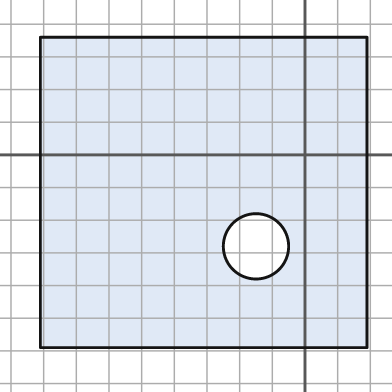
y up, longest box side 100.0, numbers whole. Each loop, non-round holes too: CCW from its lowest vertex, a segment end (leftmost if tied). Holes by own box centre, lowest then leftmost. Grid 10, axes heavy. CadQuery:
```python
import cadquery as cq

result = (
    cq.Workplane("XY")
    .moveTo(-81.0, -59.0)
    .lineTo(19.0, -59.0)
    .lineTo(19.0, 36.0)
    .lineTo(-81.0, 36.0)
    .close()
    .moveTo(-15.0, -28.0)
    .circle(10.0)
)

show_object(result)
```